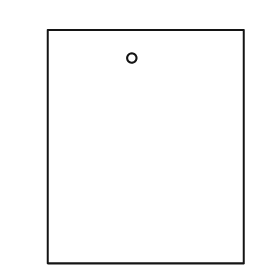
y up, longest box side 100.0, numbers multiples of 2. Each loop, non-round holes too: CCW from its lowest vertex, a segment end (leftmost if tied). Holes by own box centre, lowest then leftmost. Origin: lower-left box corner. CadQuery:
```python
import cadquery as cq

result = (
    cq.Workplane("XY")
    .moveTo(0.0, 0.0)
    .lineTo(84.0, 0.0)
    .lineTo(84.0, 100.0)
    .lineTo(0.0, 100.0)
    .close()
    .moveTo(36.0, 88.0)
    .circle(2.0)
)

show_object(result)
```